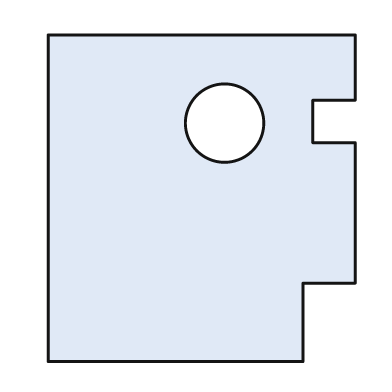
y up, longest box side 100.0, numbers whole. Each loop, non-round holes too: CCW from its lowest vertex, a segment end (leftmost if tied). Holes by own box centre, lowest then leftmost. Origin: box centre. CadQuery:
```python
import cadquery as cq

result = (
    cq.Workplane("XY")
    .moveTo(-47.0, -50.0)
    .lineTo(31.0, -50.0)
    .lineTo(31.0, -26.0)
    .lineTo(47.0, -26.0)
    .lineTo(47.0, 17.0)
    .lineTo(34.0, 17.0)
    .lineTo(34.0, 30.0)
    .lineTo(47.0, 30.0)
    .lineTo(47.0, 50.0)
    .lineTo(-47.0, 50.0)
    .close()
    .moveTo(7.0, 23.0)
    .circle(12.0)
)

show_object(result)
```